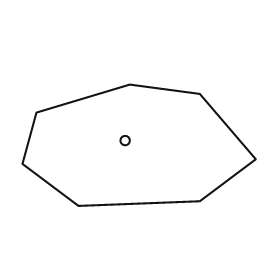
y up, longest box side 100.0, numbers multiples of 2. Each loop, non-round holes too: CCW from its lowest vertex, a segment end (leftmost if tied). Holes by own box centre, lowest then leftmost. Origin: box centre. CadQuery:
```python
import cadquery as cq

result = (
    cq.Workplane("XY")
    .moveTo(-26.0, -26.0)
    .lineTo(26.0, -24.0)
    .lineTo(50.0, -6.0)
    .lineTo(26.0, 22.0)
    .lineTo(-4.0, 26.0)
    .lineTo(-44.0, 14.0)
    .lineTo(-50.0, -8.0)
    .close()
    .moveTo(-6.0, 2.0)
    .circle(2.0)
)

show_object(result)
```